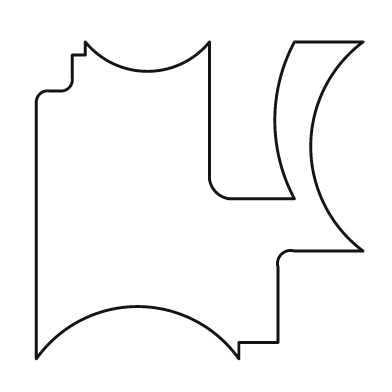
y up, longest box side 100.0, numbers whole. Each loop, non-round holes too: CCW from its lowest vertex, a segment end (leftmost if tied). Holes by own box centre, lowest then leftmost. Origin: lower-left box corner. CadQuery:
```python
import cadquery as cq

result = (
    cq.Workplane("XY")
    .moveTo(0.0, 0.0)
    .threePointArc((31.0, 16.0), (62.0, 0.0))
    .lineTo(62.0, 5.0)
    .lineTo(74.0, 5.0)
    .lineTo(74.0, 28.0)
    .threePointArc((75.0, 32.0), (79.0, 33.0))
    .lineTo(100.0, 33.0)
    .threePointArc((84.0, 65.0), (100.0, 97.0))
    .lineTo(79.0, 97.0)
    .threePointArc((73.0, 73.0), (79.0, 49.0))
    .lineTo(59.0, 49.0)
    .threePointArc((55.0, 51.0), (53.0, 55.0))
    .lineTo(53.0, 97.0)
    .threePointArc((34.0, 88.0), (15.0, 97.0))
    .lineTo(15.0, 93.0)
    .lineTo(11.0, 93.0)
    .lineTo(11.0, 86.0)
    .threePointArc((10.0, 83.0), (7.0, 82.0))
    .lineTo(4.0, 82.0)
    .threePointArc((1.0, 81.0), (0.0, 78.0))
    .close()
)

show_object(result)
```